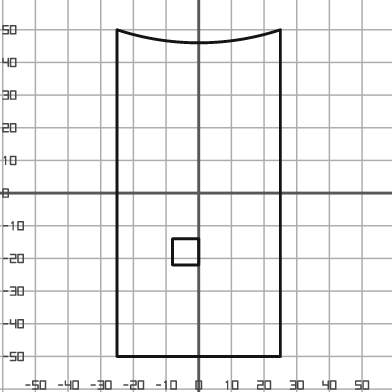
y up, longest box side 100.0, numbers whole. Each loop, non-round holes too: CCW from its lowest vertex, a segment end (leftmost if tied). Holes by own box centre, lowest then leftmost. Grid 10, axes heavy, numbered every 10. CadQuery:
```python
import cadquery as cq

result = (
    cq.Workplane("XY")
    .moveTo(-25.0, -50.0)
    .lineTo(25.0, -50.0)
    .lineTo(25.0, 50.0)
    .threePointArc((0.0, 46.0), (-25.0, 50.0))
    .close()
    .moveTo(-8.0, -22.0)
    .lineTo(0.0, -22.0)
    .lineTo(0.0, -14.0)
    .lineTo(-8.0, -14.0)
    .close()
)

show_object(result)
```